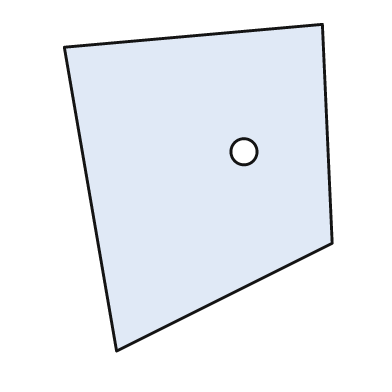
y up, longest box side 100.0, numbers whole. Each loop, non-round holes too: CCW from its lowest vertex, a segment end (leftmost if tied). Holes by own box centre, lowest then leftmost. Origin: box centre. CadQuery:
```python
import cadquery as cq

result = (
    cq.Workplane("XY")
    .moveTo(-25.0, -50.0)
    .lineTo(41.0, -17.0)
    .lineTo(38.0, 50.0)
    .lineTo(-41.0, 43.0)
    .close()
    .moveTo(14.0, 11.0)
    .circle(4.0)
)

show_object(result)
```